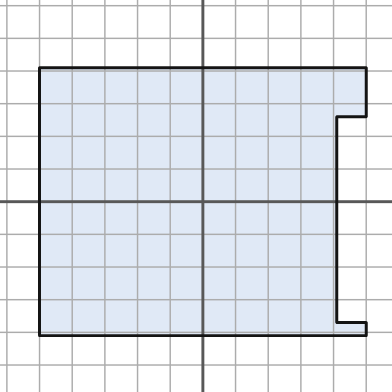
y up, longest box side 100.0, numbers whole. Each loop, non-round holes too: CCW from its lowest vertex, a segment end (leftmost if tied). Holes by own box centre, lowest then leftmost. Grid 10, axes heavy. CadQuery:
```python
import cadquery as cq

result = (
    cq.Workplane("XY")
    .moveTo(-50.0, -41.0)
    .lineTo(50.0, -41.0)
    .lineTo(50.0, -37.0)
    .lineTo(41.0, -37.0)
    .lineTo(41.0, 26.0)
    .lineTo(50.0, 26.0)
    .lineTo(50.0, 41.0)
    .lineTo(-50.0, 41.0)
    .close()
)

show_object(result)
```